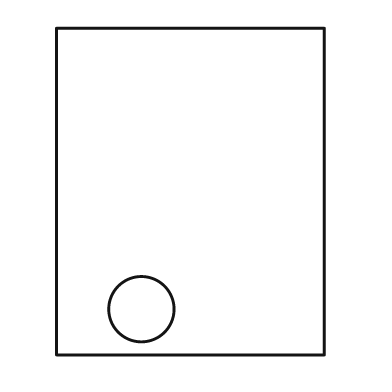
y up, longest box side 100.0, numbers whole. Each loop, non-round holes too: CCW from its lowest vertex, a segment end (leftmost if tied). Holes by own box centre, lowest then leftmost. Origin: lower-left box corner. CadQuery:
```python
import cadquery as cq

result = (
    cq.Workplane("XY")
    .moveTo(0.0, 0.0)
    .lineTo(82.0, 0.0)
    .lineTo(82.0, 100.0)
    .lineTo(0.0, 100.0)
    .close()
    .moveTo(26.0, 14.0)
    .circle(10.0)
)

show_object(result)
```